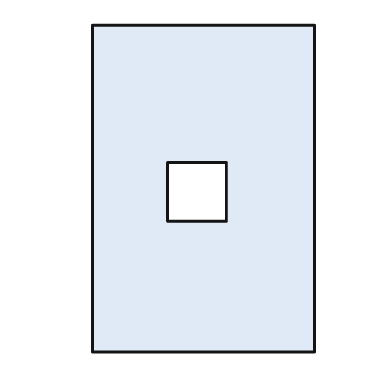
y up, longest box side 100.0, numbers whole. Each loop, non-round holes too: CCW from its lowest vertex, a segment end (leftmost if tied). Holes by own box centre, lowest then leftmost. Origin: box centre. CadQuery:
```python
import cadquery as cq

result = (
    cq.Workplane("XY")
    .moveTo(-34.0, -50.0)
    .lineTo(34.0, -50.0)
    .lineTo(34.0, 50.0)
    .lineTo(-34.0, 50.0)
    .close()
    .moveTo(-11.0, -10.0)
    .lineTo(7.0, -10.0)
    .lineTo(7.0, 8.0)
    .lineTo(-11.0, 8.0)
    .close()
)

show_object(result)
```